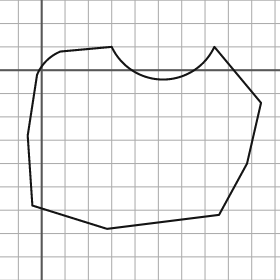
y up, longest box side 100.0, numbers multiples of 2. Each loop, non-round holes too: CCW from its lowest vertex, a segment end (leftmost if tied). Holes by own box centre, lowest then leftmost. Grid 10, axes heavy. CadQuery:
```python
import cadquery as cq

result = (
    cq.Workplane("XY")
    .moveTo(28.0, -68.0)
    .lineTo(76.0, -62.0)
    .lineTo(88.0, -40.0)
    .lineTo(94.0, -14.0)
    .lineTo(74.0, 10.0)
    .threePointArc((52.0, -4.0), (30.0, 10.0))
    .lineTo(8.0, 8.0)
    .threePointArc((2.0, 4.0), (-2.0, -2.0))
    .lineTo(-6.0, -28.0)
    .lineTo(-4.0, -58.0)
    .close()
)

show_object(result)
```